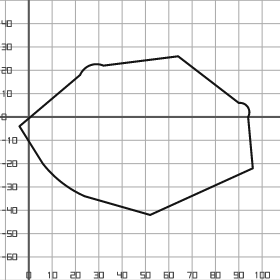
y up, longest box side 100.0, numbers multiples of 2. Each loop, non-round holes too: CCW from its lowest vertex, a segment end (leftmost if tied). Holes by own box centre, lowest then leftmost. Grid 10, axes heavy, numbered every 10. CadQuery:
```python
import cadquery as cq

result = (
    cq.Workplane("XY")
    .moveTo(52.0, -42.0)
    .lineTo(96.0, -22.0)
    .lineTo(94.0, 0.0)
    .threePointArc((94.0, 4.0), (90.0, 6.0))
    .lineTo(64.0, 26.0)
    .lineTo(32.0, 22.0)
    .threePointArc((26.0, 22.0), (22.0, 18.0))
    .lineTo(-4.0, -4.0)
    .lineTo(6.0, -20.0)
    .threePointArc((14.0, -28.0), (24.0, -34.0))
    .close()
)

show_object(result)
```